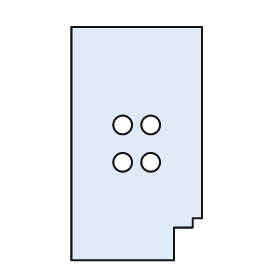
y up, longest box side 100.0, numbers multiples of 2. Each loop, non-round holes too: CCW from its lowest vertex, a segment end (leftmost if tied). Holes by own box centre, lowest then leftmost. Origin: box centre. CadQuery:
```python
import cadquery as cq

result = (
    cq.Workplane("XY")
    .moveTo(-28.0, -50.0)
    .lineTo(16.0, -50.0)
    .lineTo(16.0, -36.0)
    .lineTo(24.0, -36.0)
    .lineTo(24.0, -32.0)
    .lineTo(28.0, -32.0)
    .lineTo(28.0, 50.0)
    .lineTo(-28.0, 50.0)
    .close()
    .moveTo(-6.0, -8.0)
    .circle(4.0)
    .moveTo(6.0, -8.0)
    .circle(4.0)
    .moveTo(-6.0, 8.0)
    .circle(4.0)
    .moveTo(6.0, 8.0)
    .circle(4.0)
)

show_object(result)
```